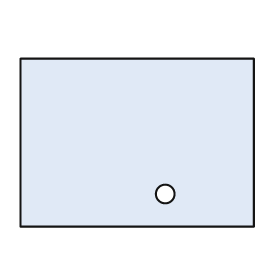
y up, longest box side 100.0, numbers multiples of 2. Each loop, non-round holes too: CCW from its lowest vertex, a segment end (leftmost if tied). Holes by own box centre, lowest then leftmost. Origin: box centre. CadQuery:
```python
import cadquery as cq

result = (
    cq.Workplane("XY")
    .moveTo(-50.0, -36.0)
    .lineTo(50.0, -36.0)
    .lineTo(50.0, 36.0)
    .lineTo(-50.0, 36.0)
    .close()
    .moveTo(12.0, -22.0)
    .circle(4.0)
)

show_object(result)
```